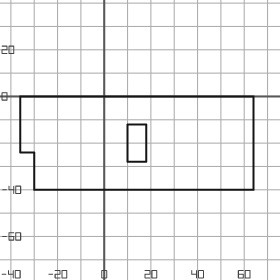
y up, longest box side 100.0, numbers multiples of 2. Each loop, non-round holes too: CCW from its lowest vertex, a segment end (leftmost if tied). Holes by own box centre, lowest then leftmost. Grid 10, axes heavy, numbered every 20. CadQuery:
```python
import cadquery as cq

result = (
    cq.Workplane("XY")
    .moveTo(-30.0, -40.0)
    .lineTo(64.0, -40.0)
    .lineTo(64.0, 0.0)
    .lineTo(-36.0, 0.0)
    .lineTo(-36.0, -24.0)
    .lineTo(-30.0, -24.0)
    .close()
    .moveTo(10.0, -28.0)
    .lineTo(18.0, -28.0)
    .lineTo(18.0, -12.0)
    .lineTo(10.0, -12.0)
    .close()
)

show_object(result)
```